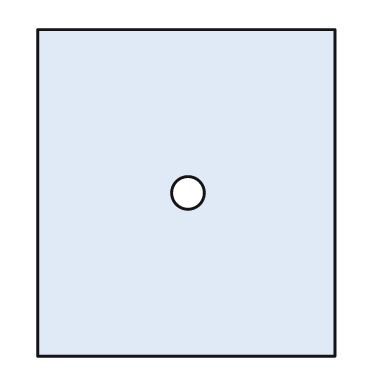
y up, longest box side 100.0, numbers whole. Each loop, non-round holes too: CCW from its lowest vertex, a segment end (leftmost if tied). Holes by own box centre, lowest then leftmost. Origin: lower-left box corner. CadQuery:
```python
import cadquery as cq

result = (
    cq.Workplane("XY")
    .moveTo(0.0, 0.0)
    .lineTo(91.0, 0.0)
    .lineTo(91.0, 100.0)
    .lineTo(0.0, 100.0)
    .close()
    .moveTo(46.0, 50.0)
    .circle(5.0)
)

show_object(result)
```